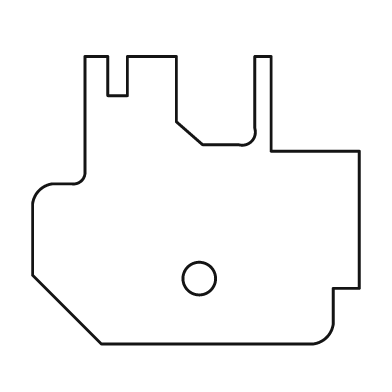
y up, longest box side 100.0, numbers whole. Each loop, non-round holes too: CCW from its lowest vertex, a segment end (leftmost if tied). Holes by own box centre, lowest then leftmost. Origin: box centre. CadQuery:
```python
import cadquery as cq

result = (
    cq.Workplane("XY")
    .moveTo(-29.0, -44.0)
    .lineTo(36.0, -44.0)
    .threePointArc((40.0, -42.0), (42.0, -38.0))
    .lineTo(42.0, -27.0)
    .lineTo(50.0, -27.0)
    .lineTo(50.0, 15.0)
    .lineTo(23.0, 15.0)
    .lineTo(23.0, 44.0)
    .lineTo(18.0, 44.0)
    .lineTo(18.0, 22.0)
    .threePointArc((17.0, 18.0), (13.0, 17.0))
    .lineTo(2.0, 17.0)
    .lineTo(-6.0, 24.0)
    .lineTo(-6.0, 44.0)
    .lineTo(-21.0, 44.0)
    .lineTo(-21.0, 32.0)
    .lineTo(-27.0, 32.0)
    .lineTo(-27.0, 44.0)
    .lineTo(-34.0, 44.0)
    .lineTo(-34.0, 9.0)
    .threePointArc((-35.0, 6.0), (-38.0, 5.0))
    .lineTo(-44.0, 5.0)
    .threePointArc((-48.0, 3.0), (-50.0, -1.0))
    .lineTo(-50.0, -23.0)
    .close()
    .moveTo(1.0, -24.0)
    .circle(5.0)
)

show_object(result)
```